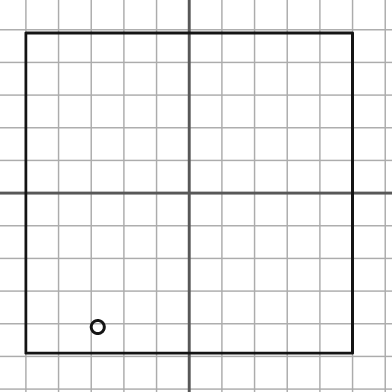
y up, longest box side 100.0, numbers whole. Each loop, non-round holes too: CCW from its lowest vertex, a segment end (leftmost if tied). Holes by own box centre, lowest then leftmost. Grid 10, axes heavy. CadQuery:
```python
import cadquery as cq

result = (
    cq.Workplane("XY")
    .moveTo(-50.0, -49.0)
    .lineTo(50.0, -49.0)
    .lineTo(50.0, 49.0)
    .lineTo(-50.0, 49.0)
    .close()
    .moveTo(-28.0, -41.0)
    .circle(2.0)
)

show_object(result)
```